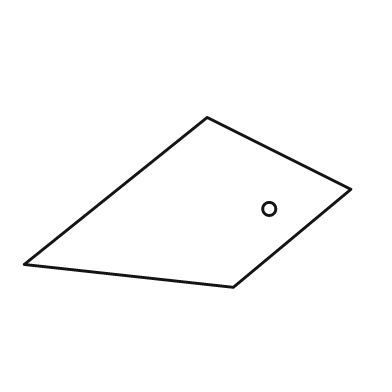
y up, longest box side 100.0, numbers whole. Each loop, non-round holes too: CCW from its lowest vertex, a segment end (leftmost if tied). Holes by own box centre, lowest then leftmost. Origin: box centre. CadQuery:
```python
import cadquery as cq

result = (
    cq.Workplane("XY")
    .moveTo(14.0, -26.0)
    .lineTo(50.0, 4.0)
    .lineTo(6.0, 26.0)
    .lineTo(-50.0, -19.0)
    .close()
    .moveTo(25.0, -2.0)
    .circle(2.0)
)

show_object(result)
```